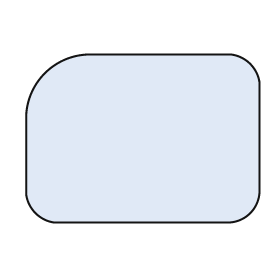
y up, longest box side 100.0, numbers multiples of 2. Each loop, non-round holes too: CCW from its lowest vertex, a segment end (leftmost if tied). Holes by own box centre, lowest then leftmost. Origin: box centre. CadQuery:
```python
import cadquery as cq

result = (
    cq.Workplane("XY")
    .moveTo(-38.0, -36.0)
    .lineTo(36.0, -36.0)
    .threePointArc((46.0, -32.0), (50.0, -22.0))
    .lineTo(50.0, 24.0)
    .threePointArc((46.0, 32.0), (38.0, 36.0))
    .lineTo(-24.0, 36.0)
    .threePointArc((-42.0, 28.0), (-50.0, 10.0))
    .lineTo(-50.0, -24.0)
    .threePointArc((-46.0, -32.0), (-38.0, -36.0))
    .close()
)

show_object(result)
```